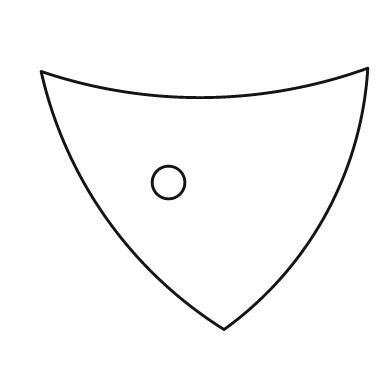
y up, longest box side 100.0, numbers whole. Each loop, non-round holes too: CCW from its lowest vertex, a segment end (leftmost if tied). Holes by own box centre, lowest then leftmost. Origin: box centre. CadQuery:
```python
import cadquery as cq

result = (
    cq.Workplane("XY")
    .moveTo(6.0, -40.0)
    .threePointArc((37.0, -5.0), (50.0, 40.0))
    .threePointArc((0.0, 31.0), (-50.0, 39.0))
    .threePointArc((-30.0, -6.0), (6.0, -40.0))
    .close()
    .moveTo(-11.0, 5.0)
    .circle(5.0)
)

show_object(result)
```